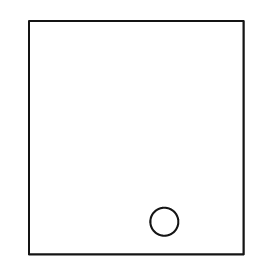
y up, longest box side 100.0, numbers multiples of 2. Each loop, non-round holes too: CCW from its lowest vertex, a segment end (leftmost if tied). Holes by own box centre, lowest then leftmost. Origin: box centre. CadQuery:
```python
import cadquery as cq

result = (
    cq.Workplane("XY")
    .moveTo(-46.0, -50.0)
    .lineTo(46.0, -50.0)
    .lineTo(46.0, 50.0)
    .lineTo(-46.0, 50.0)
    .close()
    .moveTo(12.0, -36.0)
    .circle(6.0)
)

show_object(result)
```